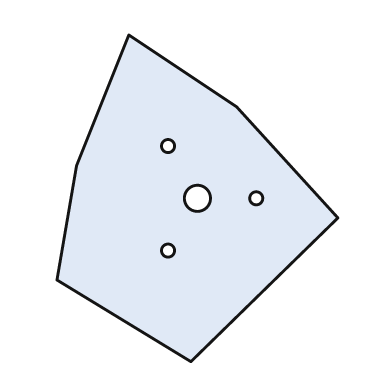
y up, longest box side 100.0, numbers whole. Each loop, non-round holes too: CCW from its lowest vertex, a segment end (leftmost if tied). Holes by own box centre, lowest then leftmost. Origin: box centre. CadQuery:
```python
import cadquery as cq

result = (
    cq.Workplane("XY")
    .moveTo(-2.0, -50.0)
    .lineTo(43.0, -6.0)
    .lineTo(12.0, 28.0)
    .lineTo(-21.0, 50.0)
    .lineTo(-37.0, 10.0)
    .lineTo(-43.0, -25.0)
    .close()
    .moveTo(-9.0, -16.0)
    .circle(2.0)
    .moveTo(0.0, 0.0)
    .circle(4.0)
    .moveTo(18.0, 0.0)
    .circle(2.0)
    .moveTo(-9.0, 16.0)
    .circle(2.0)
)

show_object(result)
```